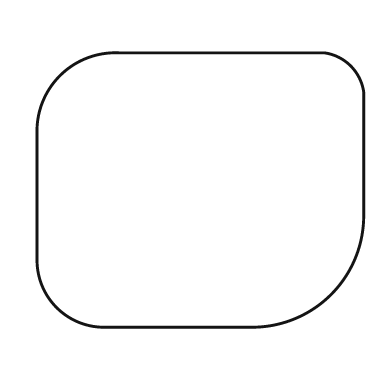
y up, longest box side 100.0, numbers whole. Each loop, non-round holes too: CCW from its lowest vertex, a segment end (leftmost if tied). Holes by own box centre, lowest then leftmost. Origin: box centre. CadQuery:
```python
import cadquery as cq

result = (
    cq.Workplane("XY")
    .moveTo(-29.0, -42.0)
    .lineTo(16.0, -42.0)
    .threePointArc((40.0, -32.0), (50.0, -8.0))
    .lineTo(50.0, 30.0)
    .threePointArc((46.0, 38.0), (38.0, 42.0))
    .lineTo(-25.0, 42.0)
    .threePointArc((-43.0, 35.0), (-50.0, 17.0))
    .lineTo(-50.0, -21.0)
    .threePointArc((-44.0, -36.0), (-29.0, -42.0))
    .close()
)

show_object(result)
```